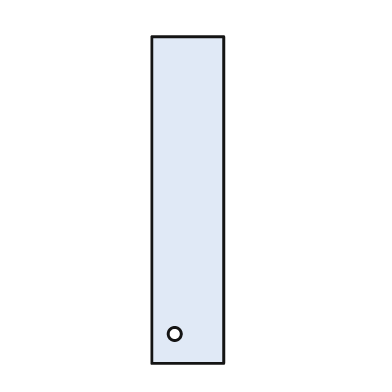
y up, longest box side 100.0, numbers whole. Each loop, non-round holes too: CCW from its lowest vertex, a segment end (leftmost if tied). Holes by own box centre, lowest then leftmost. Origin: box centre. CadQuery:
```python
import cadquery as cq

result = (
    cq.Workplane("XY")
    .moveTo(-11.0, -50.0)
    .lineTo(11.0, -50.0)
    .lineTo(11.0, 50.0)
    .lineTo(-11.0, 50.0)
    .close()
    .moveTo(-4.0, -41.0)
    .circle(2.0)
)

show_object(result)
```